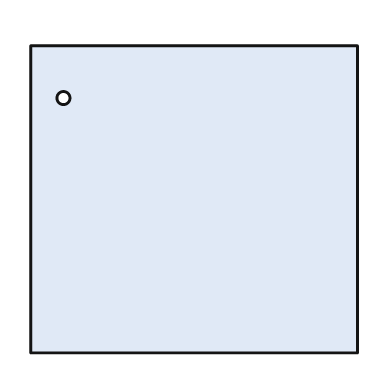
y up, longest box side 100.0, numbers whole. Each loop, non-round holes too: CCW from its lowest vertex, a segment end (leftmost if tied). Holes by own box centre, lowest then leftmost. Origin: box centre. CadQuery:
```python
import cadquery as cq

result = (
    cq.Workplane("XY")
    .moveTo(-50.0, -47.0)
    .lineTo(50.0, -47.0)
    .lineTo(50.0, 47.0)
    .lineTo(-50.0, 47.0)
    .close()
    .moveTo(-40.0, 31.0)
    .circle(2.0)
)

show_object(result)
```